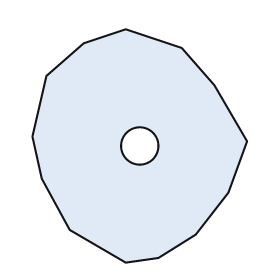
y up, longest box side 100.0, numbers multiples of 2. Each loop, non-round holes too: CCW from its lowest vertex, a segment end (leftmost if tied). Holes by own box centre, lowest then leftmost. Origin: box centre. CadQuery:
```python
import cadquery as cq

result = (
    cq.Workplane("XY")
    .moveTo(-6.0, -50.0)
    .lineTo(8.0, -48.0)
    .lineTo(24.0, -38.0)
    .lineTo(38.0, -20.0)
    .lineTo(46.0, 2.0)
    .lineTo(32.0, 26.0)
    .lineTo(18.0, 42.0)
    .lineTo(-6.0, 50.0)
    .lineTo(-24.0, 44.0)
    .lineTo(-40.0, 30.0)
    .lineTo(-46.0, 4.0)
    .lineTo(-42.0, -14.0)
    .lineTo(-30.0, -36.0)
    .close()
    .moveTo(0.0, 0.0)
    .circle(8.0)
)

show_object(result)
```